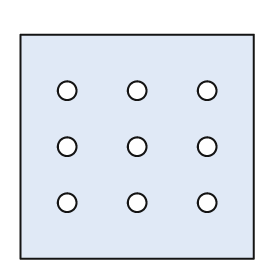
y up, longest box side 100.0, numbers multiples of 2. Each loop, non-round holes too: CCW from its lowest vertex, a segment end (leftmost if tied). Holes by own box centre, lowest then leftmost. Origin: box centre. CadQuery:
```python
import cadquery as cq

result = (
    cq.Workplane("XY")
    .moveTo(-50.0, -48.0)
    .lineTo(50.0, -48.0)
    .lineTo(50.0, 48.0)
    .lineTo(-50.0, 48.0)
    .close()
    .moveTo(-30.0, -24.0)
    .circle(4.0)
    .moveTo(0.0, -24.0)
    .circle(4.0)
    .moveTo(30.0, -24.0)
    .circle(4.0)
    .moveTo(-30.0, 0.0)
    .circle(4.0)
    .moveTo(0.0, 0.0)
    .circle(4.0)
    .moveTo(30.0, 0.0)
    .circle(4.0)
    .moveTo(-30.0, 24.0)
    .circle(4.0)
    .moveTo(0.0, 24.0)
    .circle(4.0)
    .moveTo(30.0, 24.0)
    .circle(4.0)
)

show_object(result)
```